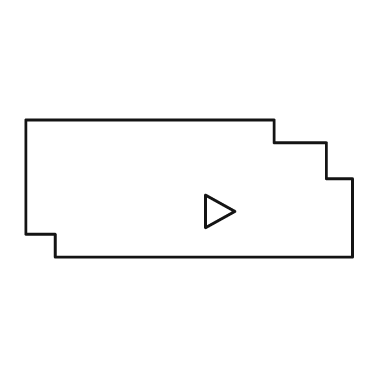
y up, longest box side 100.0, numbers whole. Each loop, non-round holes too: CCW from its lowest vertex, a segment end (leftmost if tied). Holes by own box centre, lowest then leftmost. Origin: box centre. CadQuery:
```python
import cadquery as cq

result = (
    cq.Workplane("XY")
    .moveTo(-41.0, -21.0)
    .lineTo(50.0, -21.0)
    .lineTo(50.0, 3.0)
    .lineTo(42.0, 3.0)
    .lineTo(42.0, 14.0)
    .lineTo(26.0, 14.0)
    .lineTo(26.0, 21.0)
    .lineTo(-50.0, 21.0)
    .lineTo(-50.0, -14.0)
    .lineTo(-41.0, -14.0)
    .close()
    .moveTo(5.0, -12.0)
    .lineTo(14.0, -7.0)
    .lineTo(5.0, -2.0)
    .close()
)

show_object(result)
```